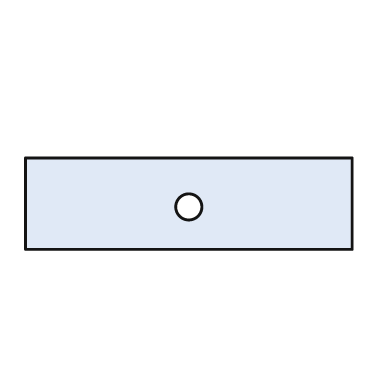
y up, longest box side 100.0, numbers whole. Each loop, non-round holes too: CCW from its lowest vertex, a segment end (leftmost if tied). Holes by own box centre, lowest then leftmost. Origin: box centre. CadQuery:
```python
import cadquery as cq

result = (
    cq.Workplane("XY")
    .moveTo(-50.0, -14.0)
    .lineTo(50.0, -14.0)
    .lineTo(50.0, 14.0)
    .lineTo(-50.0, 14.0)
    .close()
    .moveTo(0.0, -1.0)
    .circle(4.0)
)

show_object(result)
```